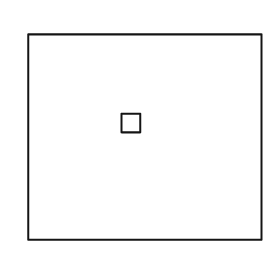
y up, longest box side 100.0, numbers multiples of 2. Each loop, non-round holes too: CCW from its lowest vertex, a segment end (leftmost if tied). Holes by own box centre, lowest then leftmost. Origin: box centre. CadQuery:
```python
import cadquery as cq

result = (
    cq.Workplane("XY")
    .moveTo(-50.0, -44.0)
    .lineTo(50.0, -44.0)
    .lineTo(50.0, 44.0)
    .lineTo(-50.0, 44.0)
    .close()
    .moveTo(-10.0, 2.0)
    .lineTo(-2.0, 2.0)
    .lineTo(-2.0, 10.0)
    .lineTo(-10.0, 10.0)
    .close()
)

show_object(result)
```